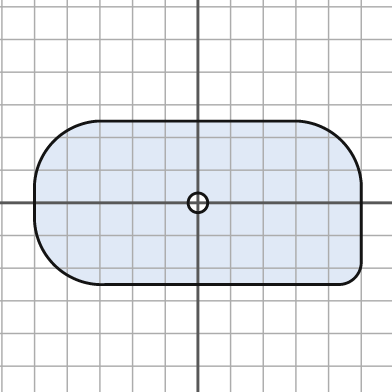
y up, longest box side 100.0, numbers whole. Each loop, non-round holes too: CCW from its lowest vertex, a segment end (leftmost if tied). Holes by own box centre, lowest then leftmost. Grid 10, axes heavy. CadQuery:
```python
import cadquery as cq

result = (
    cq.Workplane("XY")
    .moveTo(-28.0, -25.0)
    .lineTo(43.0, -25.0)
    .threePointArc((48.0, -23.0), (50.0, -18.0))
    .lineTo(50.0, 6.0)
    .threePointArc((44.0, 19.0), (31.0, 25.0))
    .lineTo(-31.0, 25.0)
    .threePointArc((-44.0, 19.0), (-50.0, 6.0))
    .lineTo(-50.0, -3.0)
    .threePointArc((-44.0, -19.0), (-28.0, -25.0))
    .close()
    .moveTo(0.0, 0.0)
    .circle(3.0)
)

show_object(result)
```